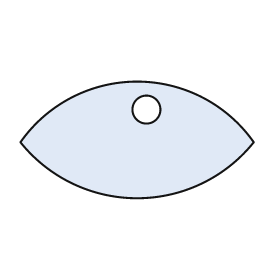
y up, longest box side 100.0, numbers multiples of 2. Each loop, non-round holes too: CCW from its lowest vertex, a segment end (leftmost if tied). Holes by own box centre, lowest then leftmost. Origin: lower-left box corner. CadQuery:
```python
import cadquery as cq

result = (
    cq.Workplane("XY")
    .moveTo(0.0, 24.0)
    .threePointArc((50.0, 0.0), (100.0, 24.0))
    .threePointArc((50.0, 50.0), (0.0, 24.0))
    .close()
    .moveTo(54.0, 38.0)
    .circle(6.0)
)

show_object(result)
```